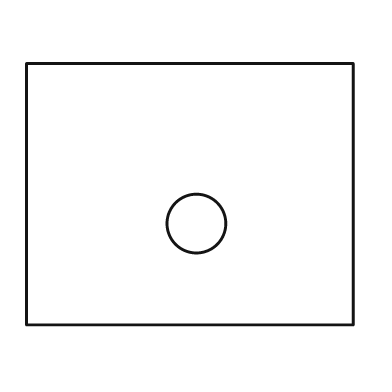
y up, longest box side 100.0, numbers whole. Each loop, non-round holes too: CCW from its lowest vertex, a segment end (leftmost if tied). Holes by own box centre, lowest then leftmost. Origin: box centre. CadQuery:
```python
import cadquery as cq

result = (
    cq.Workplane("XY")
    .moveTo(-50.0, -40.0)
    .lineTo(50.0, -40.0)
    .lineTo(50.0, 40.0)
    .lineTo(-50.0, 40.0)
    .close()
    .moveTo(2.0, -9.0)
    .circle(9.0)
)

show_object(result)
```